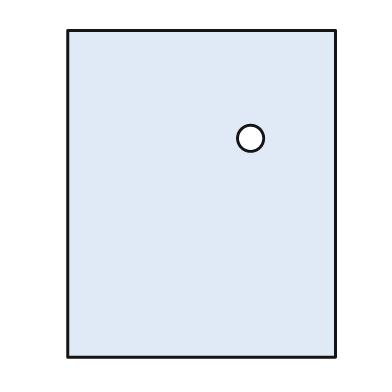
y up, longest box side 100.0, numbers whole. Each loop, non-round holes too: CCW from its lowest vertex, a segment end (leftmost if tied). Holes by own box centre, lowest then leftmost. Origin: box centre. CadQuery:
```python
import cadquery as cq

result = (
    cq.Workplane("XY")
    .moveTo(-41.0, -50.0)
    .lineTo(41.0, -50.0)
    .lineTo(41.0, 50.0)
    .lineTo(-41.0, 50.0)
    .close()
    .moveTo(15.0, 17.0)
    .circle(4.0)
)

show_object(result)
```